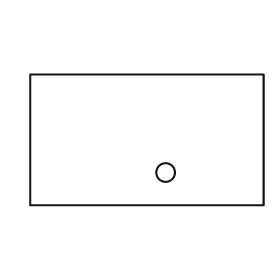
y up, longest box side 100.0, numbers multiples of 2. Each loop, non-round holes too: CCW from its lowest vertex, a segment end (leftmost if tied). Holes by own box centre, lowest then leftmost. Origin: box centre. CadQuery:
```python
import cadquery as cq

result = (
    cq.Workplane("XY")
    .moveTo(-50.0, -28.0)
    .lineTo(50.0, -28.0)
    .lineTo(50.0, 28.0)
    .lineTo(-50.0, 28.0)
    .close()
    .moveTo(8.0, -14.0)
    .circle(4.0)
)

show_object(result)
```